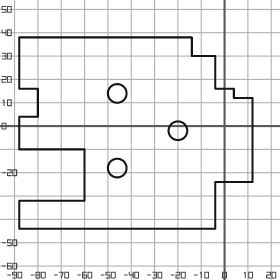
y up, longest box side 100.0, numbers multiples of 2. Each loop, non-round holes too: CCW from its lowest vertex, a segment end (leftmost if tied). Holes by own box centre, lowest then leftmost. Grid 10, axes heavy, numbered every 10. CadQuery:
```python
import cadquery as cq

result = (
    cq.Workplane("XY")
    .moveTo(-88.0, -44.0)
    .lineTo(-4.0, -44.0)
    .lineTo(-4.0, -24.0)
    .lineTo(12.0, -24.0)
    .lineTo(12.0, 12.0)
    .lineTo(4.0, 12.0)
    .lineTo(4.0, 16.0)
    .lineTo(-4.0, 16.0)
    .lineTo(-4.0, 30.0)
    .lineTo(-14.0, 30.0)
    .lineTo(-14.0, 38.0)
    .lineTo(-88.0, 38.0)
    .lineTo(-88.0, 16.0)
    .lineTo(-80.0, 16.0)
    .lineTo(-80.0, 4.0)
    .lineTo(-88.0, 4.0)
    .lineTo(-88.0, -10.0)
    .lineTo(-60.0, -10.0)
    .lineTo(-60.0, -32.0)
    .lineTo(-88.0, -32.0)
    .close()
    .moveTo(-46.0, -18.0)
    .circle(4.0)
    .moveTo(-20.0, -2.0)
    .circle(4.0)
    .moveTo(-46.0, 14.0)
    .circle(4.0)
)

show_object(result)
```